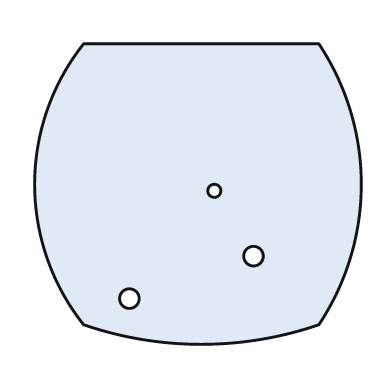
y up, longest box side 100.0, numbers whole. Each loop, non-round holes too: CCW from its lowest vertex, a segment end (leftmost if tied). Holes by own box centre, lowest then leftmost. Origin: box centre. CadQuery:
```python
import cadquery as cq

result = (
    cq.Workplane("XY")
    .moveTo(-35.0, -40.0)
    .threePointArc((1.0, -46.0), (37.0, -40.0))
    .threePointArc((50.0, 3.0), (37.0, 46.0))
    .lineTo(-35.0, 46.0)
    .threePointArc((-50.0, 3.0), (-35.0, -40.0))
    .close()
    .moveTo(-21.0, -32.0)
    .circle(3.0)
    .moveTo(17.0, -19.0)
    .circle(3.0)
    .moveTo(5.0, 1.0)
    .circle(2.0)
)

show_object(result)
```